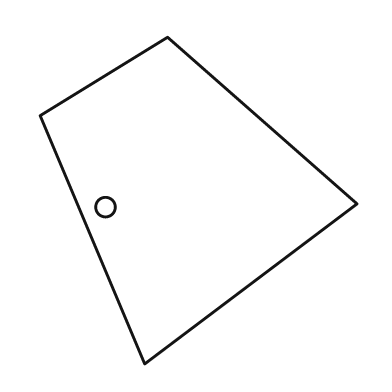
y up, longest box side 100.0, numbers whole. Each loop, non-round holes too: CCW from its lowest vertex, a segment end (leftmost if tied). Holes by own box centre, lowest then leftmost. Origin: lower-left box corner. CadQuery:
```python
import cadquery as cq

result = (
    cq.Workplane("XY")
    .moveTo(32.0, 0.0)
    .lineTo(97.0, 49.0)
    .lineTo(39.0, 100.0)
    .lineTo(0.0, 76.0)
    .close()
    .moveTo(20.0, 48.0)
    .circle(3.0)
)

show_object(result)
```